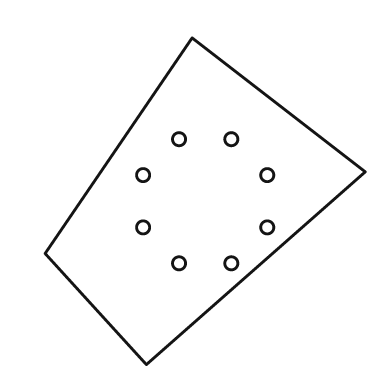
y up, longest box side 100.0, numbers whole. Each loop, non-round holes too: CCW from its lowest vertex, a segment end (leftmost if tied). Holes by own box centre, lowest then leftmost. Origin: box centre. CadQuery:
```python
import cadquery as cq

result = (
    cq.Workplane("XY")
    .moveTo(-18.0, -50.0)
    .lineTo(49.0, 9.0)
    .lineTo(-4.0, 50.0)
    .lineTo(-49.0, -16.0)
    .close()
    .moveTo(-8.0, -19.0)
    .circle(2.0)
    .moveTo(8.0, -19.0)
    .circle(2.0)
    .moveTo(-19.0, -8.0)
    .circle(2.0)
    .moveTo(19.0, -8.0)
    .circle(2.0)
    .moveTo(-19.0, 8.0)
    .circle(2.0)
    .moveTo(19.0, 8.0)
    .circle(2.0)
    .moveTo(-8.0, 19.0)
    .circle(2.0)
    .moveTo(8.0, 19.0)
    .circle(2.0)
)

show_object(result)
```